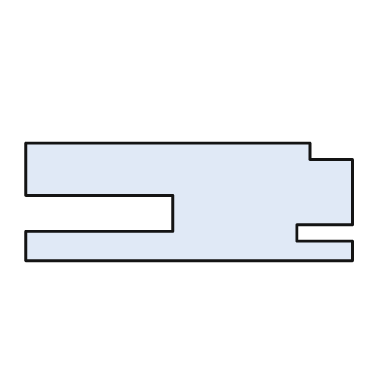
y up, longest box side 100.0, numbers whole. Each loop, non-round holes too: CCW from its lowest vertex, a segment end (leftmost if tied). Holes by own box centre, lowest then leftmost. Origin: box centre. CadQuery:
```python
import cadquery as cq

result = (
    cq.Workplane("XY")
    .moveTo(-50.0, -18.0)
    .lineTo(50.0, -18.0)
    .lineTo(50.0, -12.0)
    .lineTo(33.0, -12.0)
    .lineTo(33.0, -7.0)
    .lineTo(50.0, -7.0)
    .lineTo(50.0, 13.0)
    .lineTo(37.0, 13.0)
    .lineTo(37.0, 18.0)
    .lineTo(-50.0, 18.0)
    .lineTo(-50.0, 2.0)
    .lineTo(-5.0, 2.0)
    .lineTo(-5.0, -9.0)
    .lineTo(-50.0, -9.0)
    .close()
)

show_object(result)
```